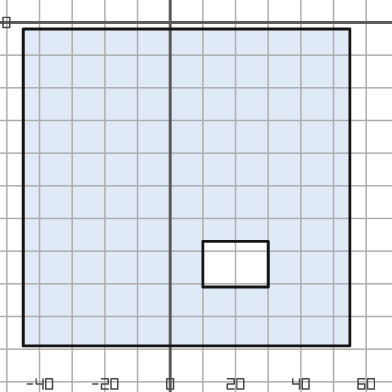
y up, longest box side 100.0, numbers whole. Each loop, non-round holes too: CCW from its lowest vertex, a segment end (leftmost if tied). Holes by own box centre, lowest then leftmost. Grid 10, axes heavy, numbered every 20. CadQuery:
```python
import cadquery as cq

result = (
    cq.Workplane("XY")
    .moveTo(-45.0, -99.0)
    .lineTo(55.0, -99.0)
    .lineTo(55.0, -2.0)
    .lineTo(-45.0, -2.0)
    .close()
    .moveTo(10.0, -81.0)
    .lineTo(30.0, -81.0)
    .lineTo(30.0, -67.0)
    .lineTo(10.0, -67.0)
    .close()
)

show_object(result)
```